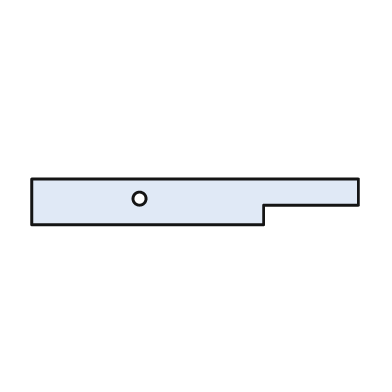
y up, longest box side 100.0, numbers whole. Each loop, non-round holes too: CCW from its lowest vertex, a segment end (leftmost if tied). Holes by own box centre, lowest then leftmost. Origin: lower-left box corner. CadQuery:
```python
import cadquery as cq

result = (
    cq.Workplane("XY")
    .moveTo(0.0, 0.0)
    .lineTo(71.0, 0.0)
    .lineTo(71.0, 6.0)
    .lineTo(100.0, 6.0)
    .lineTo(100.0, 14.0)
    .lineTo(0.0, 14.0)
    .close()
    .moveTo(33.0, 8.0)
    .circle(2.0)
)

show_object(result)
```